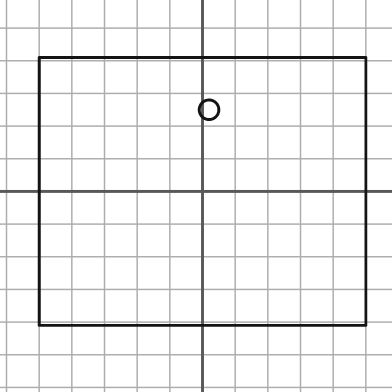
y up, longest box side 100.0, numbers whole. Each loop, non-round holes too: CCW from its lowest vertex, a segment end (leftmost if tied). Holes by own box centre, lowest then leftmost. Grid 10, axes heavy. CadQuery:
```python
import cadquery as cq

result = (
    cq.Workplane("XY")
    .moveTo(-50.0, -41.0)
    .lineTo(50.0, -41.0)
    .lineTo(50.0, 41.0)
    .lineTo(-50.0, 41.0)
    .close()
    .moveTo(2.0, 25.0)
    .circle(3.0)
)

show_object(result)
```